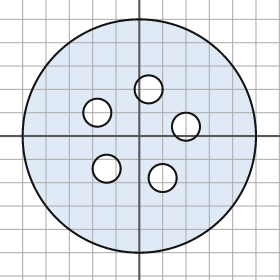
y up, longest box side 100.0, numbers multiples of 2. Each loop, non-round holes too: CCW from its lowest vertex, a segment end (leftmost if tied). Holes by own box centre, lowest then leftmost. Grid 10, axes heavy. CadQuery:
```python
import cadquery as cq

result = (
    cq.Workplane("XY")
    .moveTo(0.0, 0.0)
    .circle(50.0)
    .moveTo(10.0, -18.0)
    .circle(6.0)
    .moveTo(-14.0, -14.0)
    .circle(6.0)
    .moveTo(20.0, 4.0)
    .circle(6.0)
    .moveTo(-18.0, 10.0)
    .circle(6.0)
    .moveTo(4.0, 20.0)
    .circle(6.0)
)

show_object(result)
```